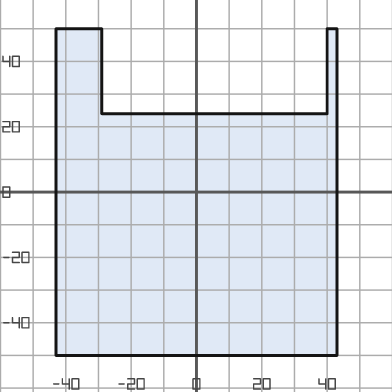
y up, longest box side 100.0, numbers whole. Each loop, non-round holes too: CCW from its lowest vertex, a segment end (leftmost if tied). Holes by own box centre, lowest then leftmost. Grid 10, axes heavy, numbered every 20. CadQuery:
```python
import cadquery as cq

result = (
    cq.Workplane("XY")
    .moveTo(-43.0, -50.0)
    .lineTo(43.0, -50.0)
    .lineTo(43.0, 50.0)
    .lineTo(40.0, 50.0)
    .lineTo(40.0, 24.0)
    .lineTo(-29.0, 24.0)
    .lineTo(-29.0, 50.0)
    .lineTo(-43.0, 50.0)
    .close()
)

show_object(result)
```